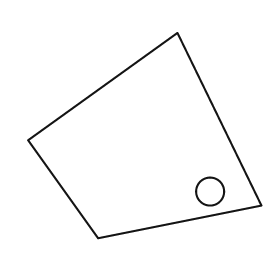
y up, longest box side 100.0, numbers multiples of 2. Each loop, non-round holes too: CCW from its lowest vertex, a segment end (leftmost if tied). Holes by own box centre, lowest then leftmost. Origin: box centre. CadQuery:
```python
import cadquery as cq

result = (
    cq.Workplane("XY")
    .moveTo(-20.0, -44.0)
    .lineTo(50.0, -30.0)
    .lineTo(14.0, 44.0)
    .lineTo(-50.0, -2.0)
    .close()
    .moveTo(28.0, -24.0)
    .circle(6.0)
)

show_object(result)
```